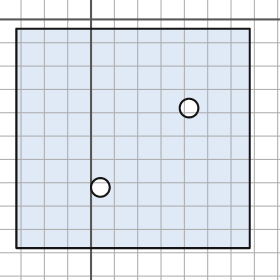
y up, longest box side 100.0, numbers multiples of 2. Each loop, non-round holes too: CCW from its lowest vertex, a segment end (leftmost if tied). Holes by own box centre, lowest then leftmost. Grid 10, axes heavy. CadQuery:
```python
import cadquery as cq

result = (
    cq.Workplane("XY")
    .moveTo(-32.0, -98.0)
    .lineTo(68.0, -98.0)
    .lineTo(68.0, -4.0)
    .lineTo(-32.0, -4.0)
    .close()
    .moveTo(4.0, -72.0)
    .circle(4.0)
    .moveTo(42.0, -38.0)
    .circle(4.0)
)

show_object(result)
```